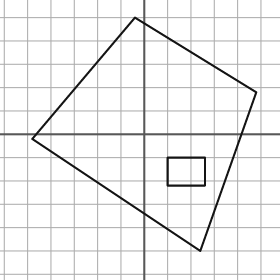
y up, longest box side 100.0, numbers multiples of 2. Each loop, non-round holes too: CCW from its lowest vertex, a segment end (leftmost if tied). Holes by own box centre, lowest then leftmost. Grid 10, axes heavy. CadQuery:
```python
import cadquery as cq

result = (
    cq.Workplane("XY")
    .moveTo(24.0, -50.0)
    .lineTo(48.0, 18.0)
    .lineTo(-4.0, 50.0)
    .lineTo(-48.0, -2.0)
    .close()
    .moveTo(10.0, -22.0)
    .lineTo(26.0, -22.0)
    .lineTo(26.0, -10.0)
    .lineTo(10.0, -10.0)
    .close()
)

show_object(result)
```